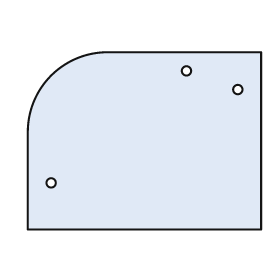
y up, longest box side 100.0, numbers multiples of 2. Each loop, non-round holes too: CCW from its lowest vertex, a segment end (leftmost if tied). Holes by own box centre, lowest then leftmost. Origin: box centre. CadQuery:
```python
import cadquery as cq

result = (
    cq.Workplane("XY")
    .moveTo(-50.0, -38.0)
    .lineTo(50.0, -38.0)
    .lineTo(50.0, 38.0)
    .lineTo(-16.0, 38.0)
    .threePointArc((-40.0, 28.0), (-50.0, 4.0))
    .close()
    .moveTo(-40.0, -18.0)
    .circle(2.0)
    .moveTo(40.0, 22.0)
    .circle(2.0)
    .moveTo(18.0, 30.0)
    .circle(2.0)
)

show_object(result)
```